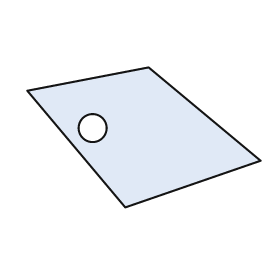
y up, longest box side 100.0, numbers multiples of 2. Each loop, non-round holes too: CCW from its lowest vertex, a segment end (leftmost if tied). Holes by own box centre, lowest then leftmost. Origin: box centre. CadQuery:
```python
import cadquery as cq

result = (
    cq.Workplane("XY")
    .moveTo(-8.0, -30.0)
    .lineTo(50.0, -10.0)
    .lineTo(2.0, 30.0)
    .lineTo(-50.0, 20.0)
    .close()
    .moveTo(-22.0, 4.0)
    .circle(6.0)
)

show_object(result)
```